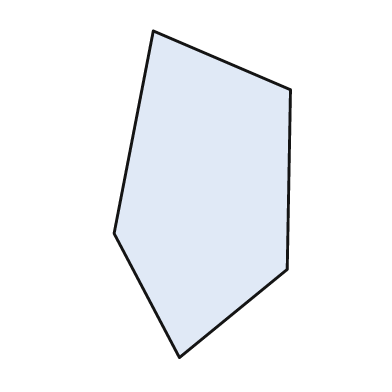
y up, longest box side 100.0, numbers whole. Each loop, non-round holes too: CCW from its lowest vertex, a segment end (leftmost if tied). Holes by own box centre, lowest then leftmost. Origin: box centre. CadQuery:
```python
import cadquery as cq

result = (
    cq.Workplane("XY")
    .moveTo(-7.0, -50.0)
    .lineTo(26.0, -23.0)
    .lineTo(27.0, 32.0)
    .lineTo(-15.0, 50.0)
    .lineTo(-27.0, -12.0)
    .close()
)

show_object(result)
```